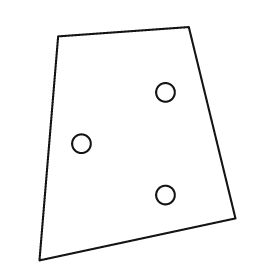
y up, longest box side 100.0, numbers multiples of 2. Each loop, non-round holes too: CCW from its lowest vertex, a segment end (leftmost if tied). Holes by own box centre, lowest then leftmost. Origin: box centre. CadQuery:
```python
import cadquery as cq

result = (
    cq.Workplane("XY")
    .moveTo(-42.0, -50.0)
    .lineTo(42.0, -32.0)
    .lineTo(22.0, 50.0)
    .lineTo(-34.0, 46.0)
    .close()
    .moveTo(12.0, -22.0)
    .circle(4.0)
    .moveTo(-24.0, 0.0)
    .circle(4.0)
    .moveTo(12.0, 22.0)
    .circle(4.0)
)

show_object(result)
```